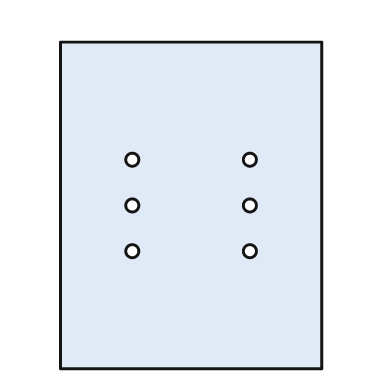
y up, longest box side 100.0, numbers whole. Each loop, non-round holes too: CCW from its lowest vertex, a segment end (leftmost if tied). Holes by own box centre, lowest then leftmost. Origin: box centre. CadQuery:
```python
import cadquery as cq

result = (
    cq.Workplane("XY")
    .moveTo(-40.0, -50.0)
    .lineTo(40.0, -50.0)
    .lineTo(40.0, 50.0)
    .lineTo(-40.0, 50.0)
    .close()
    .moveTo(-18.0, -14.0)
    .circle(2.0)
    .moveTo(18.0, -14.0)
    .circle(2.0)
    .moveTo(-18.0, 0.0)
    .circle(2.0)
    .moveTo(18.0, 0.0)
    .circle(2.0)
    .moveTo(-18.0, 14.0)
    .circle(2.0)
    .moveTo(18.0, 14.0)
    .circle(2.0)
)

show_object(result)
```